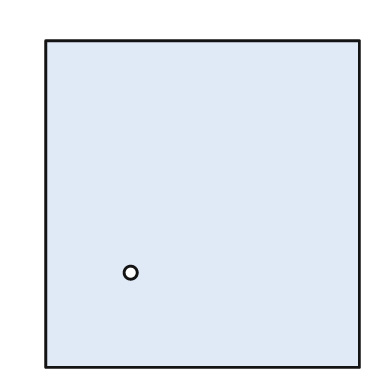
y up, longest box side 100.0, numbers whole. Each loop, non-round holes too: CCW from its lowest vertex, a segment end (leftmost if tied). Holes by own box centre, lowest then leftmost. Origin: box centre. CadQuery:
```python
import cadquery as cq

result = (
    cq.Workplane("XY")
    .moveTo(-48.0, -50.0)
    .lineTo(48.0, -50.0)
    .lineTo(48.0, 50.0)
    .lineTo(-48.0, 50.0)
    .close()
    .moveTo(-22.0, -21.0)
    .circle(2.0)
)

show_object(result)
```